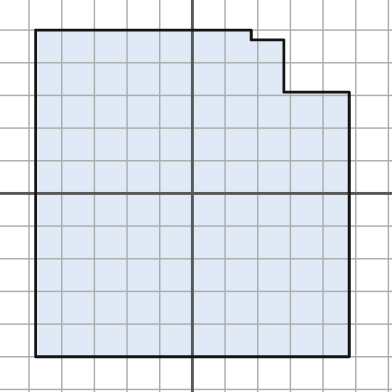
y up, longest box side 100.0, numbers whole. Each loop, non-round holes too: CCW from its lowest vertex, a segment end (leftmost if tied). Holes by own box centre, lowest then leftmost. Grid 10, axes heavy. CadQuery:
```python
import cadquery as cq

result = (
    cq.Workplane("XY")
    .moveTo(-48.0, -50.0)
    .lineTo(48.0, -50.0)
    .lineTo(48.0, 31.0)
    .lineTo(28.0, 31.0)
    .lineTo(28.0, 47.0)
    .lineTo(18.0, 47.0)
    .lineTo(18.0, 50.0)
    .lineTo(-48.0, 50.0)
    .close()
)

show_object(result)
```